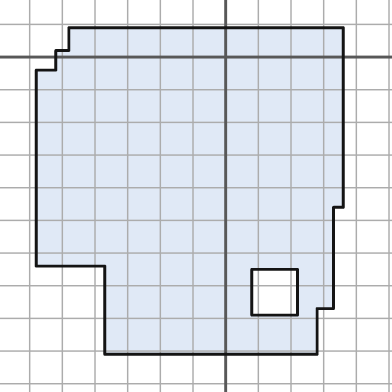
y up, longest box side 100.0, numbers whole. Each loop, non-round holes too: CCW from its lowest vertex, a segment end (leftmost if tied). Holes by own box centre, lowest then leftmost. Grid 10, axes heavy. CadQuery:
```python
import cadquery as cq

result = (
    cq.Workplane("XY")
    .moveTo(-37.0, -91.0)
    .lineTo(28.0, -91.0)
    .lineTo(28.0, -77.0)
    .lineTo(33.0, -77.0)
    .lineTo(33.0, -46.0)
    .lineTo(36.0, -46.0)
    .lineTo(36.0, 9.0)
    .lineTo(-48.0, 9.0)
    .lineTo(-48.0, 2.0)
    .lineTo(-52.0, 2.0)
    .lineTo(-52.0, -4.0)
    .lineTo(-58.0, -4.0)
    .lineTo(-58.0, -64.0)
    .lineTo(-37.0, -64.0)
    .close()
    .moveTo(8.0, -79.0)
    .lineTo(22.0, -79.0)
    .lineTo(22.0, -65.0)
    .lineTo(8.0, -65.0)
    .close()
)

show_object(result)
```